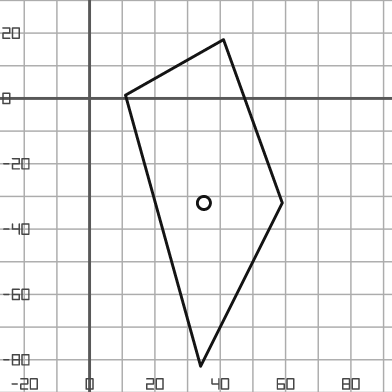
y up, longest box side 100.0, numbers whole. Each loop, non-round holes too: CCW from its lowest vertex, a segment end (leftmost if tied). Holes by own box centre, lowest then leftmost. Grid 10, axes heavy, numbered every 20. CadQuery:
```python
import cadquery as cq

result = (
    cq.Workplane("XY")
    .moveTo(34.0, -82.0)
    .lineTo(59.0, -32.0)
    .lineTo(41.0, 18.0)
    .lineTo(11.0, 1.0)
    .close()
    .moveTo(35.0, -32.0)
    .circle(2.0)
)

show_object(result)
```